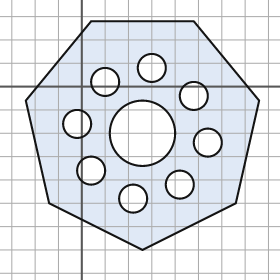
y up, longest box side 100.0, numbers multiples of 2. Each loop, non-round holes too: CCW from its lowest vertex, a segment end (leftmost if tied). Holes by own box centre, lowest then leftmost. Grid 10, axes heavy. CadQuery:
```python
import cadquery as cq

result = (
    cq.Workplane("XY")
    .moveTo(26.0, -70.0)
    .lineTo(66.0, -50.0)
    .lineTo(76.0, -6.0)
    .lineTo(48.0, 28.0)
    .lineTo(4.0, 28.0)
    .lineTo(-24.0, -6.0)
    .lineTo(-14.0, -50.0)
    .close()
    .moveTo(22.0, -48.0)
    .circle(6.0)
    .moveTo(42.0, -42.0)
    .circle(6.0)
    .moveTo(4.0, -36.0)
    .circle(6.0)
    .moveTo(54.0, -24.0)
    .circle(6.0)
    .moveTo(26.0, -20.0)
    .circle(14.0)
    .moveTo(-2.0, -16.0)
    .circle(6.0)
    .moveTo(48.0, -4.0)
    .circle(6.0)
    .moveTo(10.0, 2.0)
    .circle(6.0)
    .moveTo(30.0, 8.0)
    .circle(6.0)
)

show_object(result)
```